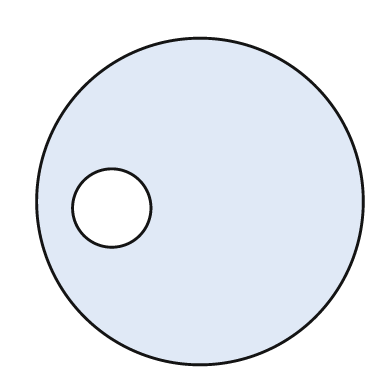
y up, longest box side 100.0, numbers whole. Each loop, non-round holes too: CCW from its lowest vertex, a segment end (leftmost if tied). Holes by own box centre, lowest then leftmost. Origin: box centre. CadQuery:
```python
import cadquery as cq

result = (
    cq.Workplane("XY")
    .moveTo(0.0, 0.0)
    .circle(50.0)
    .moveTo(-27.0, -2.0)
    .circle(12.0)
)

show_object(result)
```